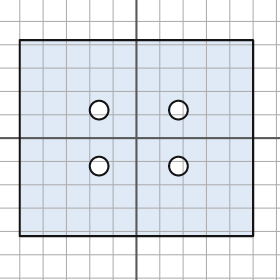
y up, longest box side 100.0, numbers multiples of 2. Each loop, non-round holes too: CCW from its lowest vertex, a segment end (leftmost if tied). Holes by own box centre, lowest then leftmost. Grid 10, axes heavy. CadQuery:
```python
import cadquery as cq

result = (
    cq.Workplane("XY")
    .moveTo(-50.0, -42.0)
    .lineTo(50.0, -42.0)
    .lineTo(50.0, 42.0)
    .lineTo(-50.0, 42.0)
    .close()
    .moveTo(-16.0, -12.0)
    .circle(4.0)
    .moveTo(18.0, -12.0)
    .circle(4.0)
    .moveTo(-16.0, 12.0)
    .circle(4.0)
    .moveTo(18.0, 12.0)
    .circle(4.0)
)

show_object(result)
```